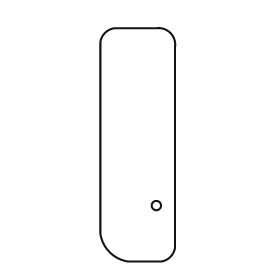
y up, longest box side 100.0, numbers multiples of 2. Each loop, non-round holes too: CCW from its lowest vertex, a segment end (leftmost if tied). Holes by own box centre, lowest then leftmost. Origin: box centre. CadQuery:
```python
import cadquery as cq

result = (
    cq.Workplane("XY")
    .moveTo(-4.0, -50.0)
    .lineTo(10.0, -50.0)
    .threePointArc((14.0, -48.0), (16.0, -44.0))
    .lineTo(16.0, 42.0)
    .threePointArc((14.0, 48.0), (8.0, 50.0))
    .lineTo(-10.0, 50.0)
    .threePointArc((-14.0, 48.0), (-16.0, 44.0))
    .lineTo(-16.0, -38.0)
    .threePointArc((-12.0, -46.0), (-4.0, -50.0))
    .close()
    .moveTo(8.0, -26.0)
    .circle(2.0)
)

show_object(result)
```